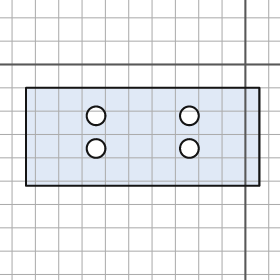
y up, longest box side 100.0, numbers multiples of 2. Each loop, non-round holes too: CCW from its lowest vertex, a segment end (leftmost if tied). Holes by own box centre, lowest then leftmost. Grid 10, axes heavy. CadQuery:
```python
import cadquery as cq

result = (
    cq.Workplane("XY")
    .moveTo(-94.0, -52.0)
    .lineTo(6.0, -52.0)
    .lineTo(6.0, -10.0)
    .lineTo(-94.0, -10.0)
    .close()
    .moveTo(-64.0, -36.0)
    .circle(4.0)
    .moveTo(-24.0, -36.0)
    .circle(4.0)
    .moveTo(-64.0, -22.0)
    .circle(4.0)
    .moveTo(-24.0, -22.0)
    .circle(4.0)
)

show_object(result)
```